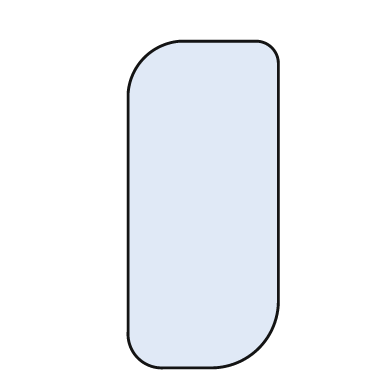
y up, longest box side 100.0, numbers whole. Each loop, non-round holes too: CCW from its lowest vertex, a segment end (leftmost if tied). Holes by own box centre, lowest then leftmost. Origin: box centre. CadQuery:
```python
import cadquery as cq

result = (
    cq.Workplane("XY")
    .moveTo(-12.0, -50.0)
    .lineTo(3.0, -50.0)
    .threePointArc((17.0, -44.0), (23.0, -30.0))
    .lineTo(23.0, 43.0)
    .threePointArc((21.0, 48.0), (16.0, 50.0))
    .lineTo(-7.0, 50.0)
    .threePointArc((-18.0, 45.0), (-23.0, 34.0))
    .lineTo(-23.0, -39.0)
    .threePointArc((-20.0, -47.0), (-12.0, -50.0))
    .close()
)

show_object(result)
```